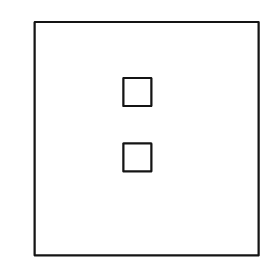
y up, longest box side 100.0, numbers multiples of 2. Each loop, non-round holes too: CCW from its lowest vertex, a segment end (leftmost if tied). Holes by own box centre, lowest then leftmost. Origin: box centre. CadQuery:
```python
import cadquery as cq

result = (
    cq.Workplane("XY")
    .moveTo(-48.0, -50.0)
    .lineTo(48.0, -50.0)
    .lineTo(48.0, 50.0)
    .lineTo(-48.0, 50.0)
    .close()
    .moveTo(-10.0, -14.0)
    .lineTo(2.0, -14.0)
    .lineTo(2.0, -2.0)
    .lineTo(-10.0, -2.0)
    .close()
    .moveTo(-10.0, 14.0)
    .lineTo(2.0, 14.0)
    .lineTo(2.0, 26.0)
    .lineTo(-10.0, 26.0)
    .close()
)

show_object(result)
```